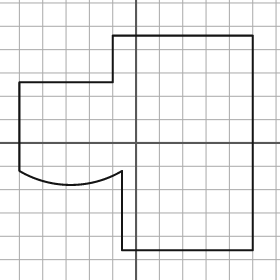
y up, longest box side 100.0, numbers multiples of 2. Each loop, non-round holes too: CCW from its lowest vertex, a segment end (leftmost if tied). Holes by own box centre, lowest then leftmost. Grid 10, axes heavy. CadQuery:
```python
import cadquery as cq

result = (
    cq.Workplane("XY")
    .moveTo(-6.0, -46.0)
    .lineTo(50.0, -46.0)
    .lineTo(50.0, 46.0)
    .lineTo(-10.0, 46.0)
    .lineTo(-10.0, 26.0)
    .lineTo(-50.0, 26.0)
    .lineTo(-50.0, -12.0)
    .threePointArc((-28.0, -18.0), (-6.0, -12.0))
    .close()
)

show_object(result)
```